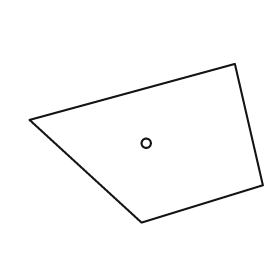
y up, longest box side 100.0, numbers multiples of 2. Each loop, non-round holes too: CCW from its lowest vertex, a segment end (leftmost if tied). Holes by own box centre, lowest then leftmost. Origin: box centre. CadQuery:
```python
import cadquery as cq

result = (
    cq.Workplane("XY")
    .moveTo(-2.0, -34.0)
    .lineTo(50.0, -18.0)
    .lineTo(38.0, 34.0)
    .lineTo(-50.0, 10.0)
    .close()
    .moveTo(0.0, 0.0)
    .circle(2.0)
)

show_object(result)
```